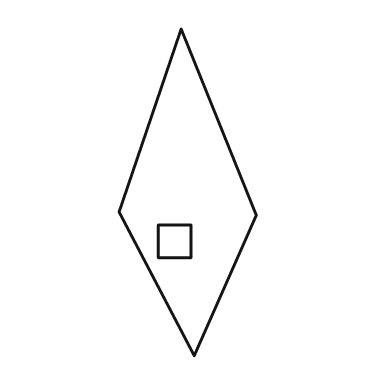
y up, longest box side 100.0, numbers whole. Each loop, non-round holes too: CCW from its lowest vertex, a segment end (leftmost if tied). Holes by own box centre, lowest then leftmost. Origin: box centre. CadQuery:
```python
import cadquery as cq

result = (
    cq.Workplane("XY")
    .moveTo(2.0, -50.0)
    .lineTo(21.0, -7.0)
    .lineTo(-2.0, 50.0)
    .lineTo(-21.0, -6.0)
    .close()
    .moveTo(-9.0, -20.0)
    .lineTo(1.0, -20.0)
    .lineTo(1.0, -10.0)
    .lineTo(-9.0, -10.0)
    .close()
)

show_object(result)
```